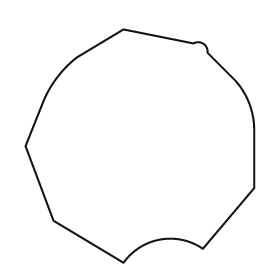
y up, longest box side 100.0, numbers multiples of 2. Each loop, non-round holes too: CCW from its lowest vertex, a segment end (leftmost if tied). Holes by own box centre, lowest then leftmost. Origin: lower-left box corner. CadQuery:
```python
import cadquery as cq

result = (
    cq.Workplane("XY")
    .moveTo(42.0, 0.0)
    .threePointArc((58.0, 10.0), (76.0, 6.0))
    .lineTo(98.0, 32.0)
    .lineTo(98.0, 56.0)
    .threePointArc((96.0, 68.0), (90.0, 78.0))
    .lineTo(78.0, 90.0)
    .threePointArc((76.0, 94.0), (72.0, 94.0))
    .lineTo(42.0, 100.0)
    .lineTo(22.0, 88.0)
    .threePointArc((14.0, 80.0), (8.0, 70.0))
    .lineTo(0.0, 50.0)
    .lineTo(12.0, 18.0)
    .close()
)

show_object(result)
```